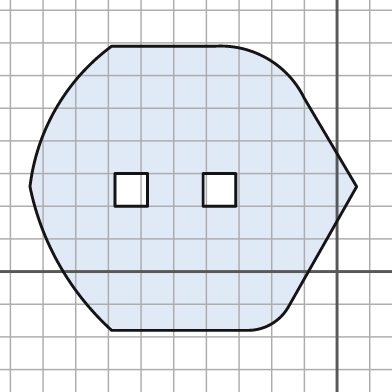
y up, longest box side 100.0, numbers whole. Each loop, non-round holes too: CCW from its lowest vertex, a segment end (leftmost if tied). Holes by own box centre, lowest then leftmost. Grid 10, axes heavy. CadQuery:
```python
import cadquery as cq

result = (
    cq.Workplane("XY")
    .moveTo(-69.0, -18.0)
    .lineTo(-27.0, -18.0)
    .threePointArc((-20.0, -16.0), (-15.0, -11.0))
    .lineTo(6.0, 26.0)
    .lineTo(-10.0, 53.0)
    .threePointArc((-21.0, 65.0), (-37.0, 69.0))
    .lineTo(-69.0, 69.0)
    .threePointArc((-86.0, 50.0), (-94.0, 26.0))
    .threePointArc((-85.0, 2.0), (-69.0, -18.0))
    .close()
    .moveTo(-68.0, 20.0)
    .lineTo(-58.0, 20.0)
    .lineTo(-58.0, 30.0)
    .lineTo(-68.0, 30.0)
    .close()
    .moveTo(-41.0, 20.0)
    .lineTo(-31.0, 20.0)
    .lineTo(-31.0, 30.0)
    .lineTo(-41.0, 30.0)
    .close()
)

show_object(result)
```